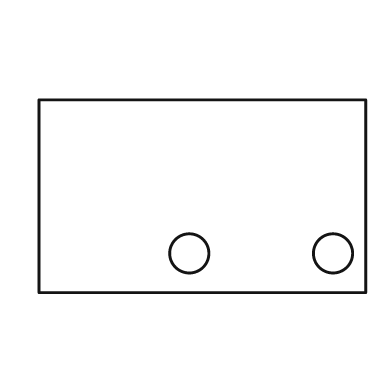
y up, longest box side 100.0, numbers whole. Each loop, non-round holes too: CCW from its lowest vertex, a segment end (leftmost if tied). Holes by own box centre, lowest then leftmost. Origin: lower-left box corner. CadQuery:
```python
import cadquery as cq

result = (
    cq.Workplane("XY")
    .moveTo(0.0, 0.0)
    .lineTo(100.0, 0.0)
    .lineTo(100.0, 59.0)
    .lineTo(0.0, 59.0)
    .close()
    .moveTo(46.0, 12.0)
    .circle(6.0)
    .moveTo(90.0, 12.0)
    .circle(6.0)
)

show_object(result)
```